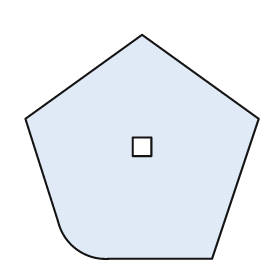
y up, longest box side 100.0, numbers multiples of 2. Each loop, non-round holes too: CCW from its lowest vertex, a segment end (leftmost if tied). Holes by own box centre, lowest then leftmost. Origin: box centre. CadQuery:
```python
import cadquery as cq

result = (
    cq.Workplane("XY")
    .moveTo(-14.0, -48.0)
    .lineTo(30.0, -48.0)
    .lineTo(50.0, 12.0)
    .lineTo(0.0, 48.0)
    .lineTo(-50.0, 12.0)
    .lineTo(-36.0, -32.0)
    .threePointArc((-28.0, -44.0), (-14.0, -48.0))
    .close()
    .moveTo(-4.0, -4.0)
    .lineTo(4.0, -4.0)
    .lineTo(4.0, 4.0)
    .lineTo(-4.0, 4.0)
    .close()
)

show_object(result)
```